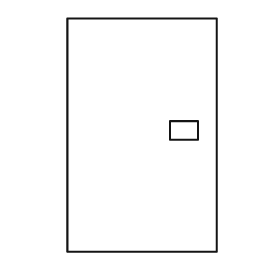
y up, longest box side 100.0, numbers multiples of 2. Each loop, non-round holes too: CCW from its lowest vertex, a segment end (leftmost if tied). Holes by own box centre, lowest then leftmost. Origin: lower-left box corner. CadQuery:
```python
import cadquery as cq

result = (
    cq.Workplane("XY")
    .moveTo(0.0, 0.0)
    .lineTo(64.0, 0.0)
    .lineTo(64.0, 100.0)
    .lineTo(0.0, 100.0)
    .close()
    .moveTo(44.0, 48.0)
    .lineTo(56.0, 48.0)
    .lineTo(56.0, 56.0)
    .lineTo(44.0, 56.0)
    .close()
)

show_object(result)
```